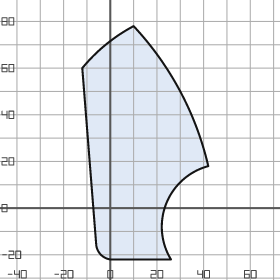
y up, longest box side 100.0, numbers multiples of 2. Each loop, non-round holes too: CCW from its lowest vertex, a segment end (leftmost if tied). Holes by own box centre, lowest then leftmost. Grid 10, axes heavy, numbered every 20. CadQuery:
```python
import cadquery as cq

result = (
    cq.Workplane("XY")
    .moveTo(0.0, -22.0)
    .lineTo(26.0, -22.0)
    .threePointArc((24.0, 2.0), (42.0, 18.0))
    .threePointArc((30.0, 50.0), (10.0, 78.0))
    .threePointArc((-2.0, 70.0), (-12.0, 60.0))
    .lineTo(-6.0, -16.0)
    .threePointArc((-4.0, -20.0), (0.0, -22.0))
    .close()
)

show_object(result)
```